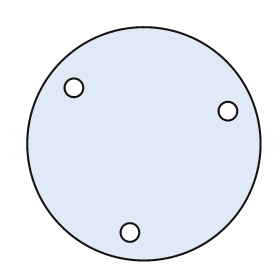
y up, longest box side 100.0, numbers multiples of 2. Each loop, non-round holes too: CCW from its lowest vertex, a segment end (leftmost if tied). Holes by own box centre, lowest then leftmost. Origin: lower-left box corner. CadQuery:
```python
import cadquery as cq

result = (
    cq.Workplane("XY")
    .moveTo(50.0, 50.0)
    .circle(50.0)
    .moveTo(44.0, 12.0)
    .circle(4.0)
    .moveTo(86.0, 64.0)
    .circle(4.0)
    .moveTo(20.0, 74.0)
    .circle(4.0)
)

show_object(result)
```